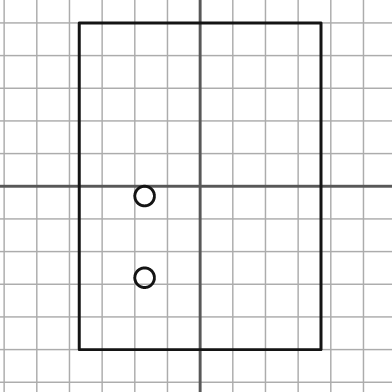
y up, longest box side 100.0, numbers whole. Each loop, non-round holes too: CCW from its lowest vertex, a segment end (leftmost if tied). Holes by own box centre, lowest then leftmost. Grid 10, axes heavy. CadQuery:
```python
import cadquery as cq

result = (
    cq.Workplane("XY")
    .moveTo(-37.0, -50.0)
    .lineTo(37.0, -50.0)
    .lineTo(37.0, 50.0)
    .lineTo(-37.0, 50.0)
    .close()
    .moveTo(-17.0, -28.0)
    .circle(3.0)
    .moveTo(-17.0, -3.0)
    .circle(3.0)
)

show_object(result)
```